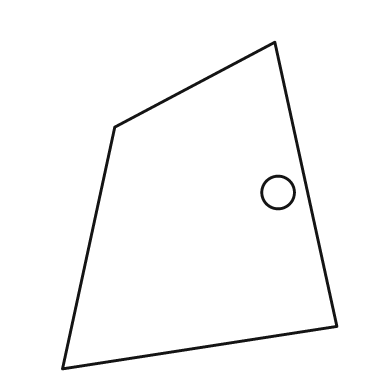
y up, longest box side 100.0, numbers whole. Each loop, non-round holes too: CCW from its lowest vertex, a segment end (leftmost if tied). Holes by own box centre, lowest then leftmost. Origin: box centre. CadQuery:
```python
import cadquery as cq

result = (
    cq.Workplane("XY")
    .moveTo(-42.0, -50.0)
    .lineTo(42.0, -37.0)
    .lineTo(23.0, 50.0)
    .lineTo(-26.0, 24.0)
    .close()
    .moveTo(24.0, 4.0)
    .circle(5.0)
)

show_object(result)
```